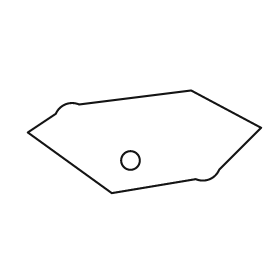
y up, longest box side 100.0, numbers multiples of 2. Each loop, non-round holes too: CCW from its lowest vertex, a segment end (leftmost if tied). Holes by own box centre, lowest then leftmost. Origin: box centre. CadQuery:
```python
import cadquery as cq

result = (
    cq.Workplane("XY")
    .moveTo(-14.0, -22.0)
    .lineTo(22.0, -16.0)
    .threePointArc((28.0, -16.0), (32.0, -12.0))
    .lineTo(50.0, 6.0)
    .lineTo(20.0, 22.0)
    .lineTo(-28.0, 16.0)
    .threePointArc((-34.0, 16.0), (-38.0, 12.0))
    .lineTo(-50.0, 4.0)
    .close()
    .moveTo(-6.0, -8.0)
    .circle(4.0)
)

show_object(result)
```